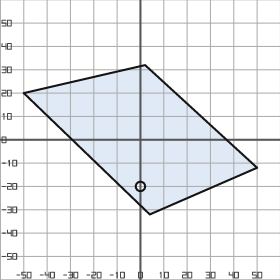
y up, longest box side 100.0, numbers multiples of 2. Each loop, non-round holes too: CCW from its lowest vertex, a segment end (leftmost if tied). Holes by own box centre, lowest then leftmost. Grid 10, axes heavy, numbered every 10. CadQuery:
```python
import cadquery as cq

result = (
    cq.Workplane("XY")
    .moveTo(4.0, -32.0)
    .lineTo(50.0, -12.0)
    .lineTo(2.0, 32.0)
    .lineTo(-50.0, 20.0)
    .close()
    .moveTo(0.0, -20.0)
    .circle(2.0)
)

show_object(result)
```